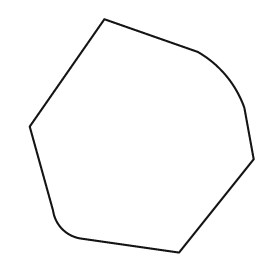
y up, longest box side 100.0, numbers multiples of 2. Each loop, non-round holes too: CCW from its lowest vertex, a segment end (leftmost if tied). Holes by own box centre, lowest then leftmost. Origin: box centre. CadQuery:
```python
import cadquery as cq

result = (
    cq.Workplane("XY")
    .moveTo(16.0, -50.0)
    .lineTo(48.0, -10.0)
    .lineTo(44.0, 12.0)
    .threePointArc((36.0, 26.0), (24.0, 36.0))
    .lineTo(-16.0, 50.0)
    .lineTo(-48.0, 4.0)
    .lineTo(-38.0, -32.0)
    .threePointArc((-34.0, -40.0), (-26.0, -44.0))
    .close()
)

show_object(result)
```